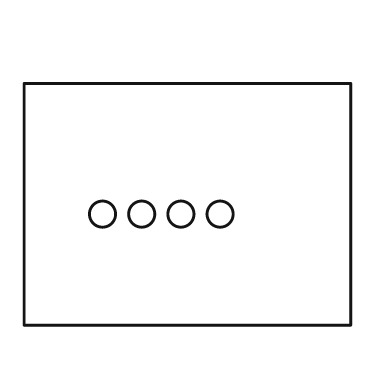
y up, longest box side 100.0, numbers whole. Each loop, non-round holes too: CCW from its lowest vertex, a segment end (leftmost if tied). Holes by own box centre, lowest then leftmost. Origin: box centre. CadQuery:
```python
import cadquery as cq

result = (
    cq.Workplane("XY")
    .moveTo(-50.0, -37.0)
    .lineTo(50.0, -37.0)
    .lineTo(50.0, 37.0)
    .lineTo(-50.0, 37.0)
    .close()
    .moveTo(-26.0, -3.0)
    .circle(4.0)
    .moveTo(-14.0, -3.0)
    .circle(4.0)
    .moveTo(-2.0, -3.0)
    .circle(4.0)
    .moveTo(10.0, -3.0)
    .circle(4.0)
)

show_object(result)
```